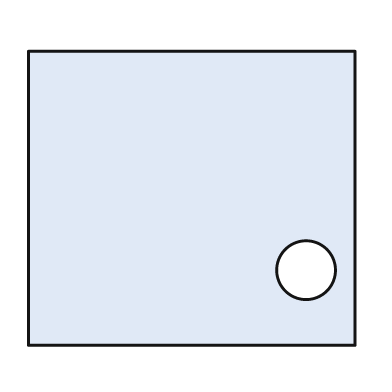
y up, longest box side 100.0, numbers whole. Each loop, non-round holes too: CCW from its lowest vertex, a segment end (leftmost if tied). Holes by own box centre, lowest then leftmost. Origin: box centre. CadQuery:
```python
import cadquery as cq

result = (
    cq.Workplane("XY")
    .moveTo(-50.0, -45.0)
    .lineTo(50.0, -45.0)
    .lineTo(50.0, 45.0)
    .lineTo(-50.0, 45.0)
    .close()
    .moveTo(35.0, -22.0)
    .circle(9.0)
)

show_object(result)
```